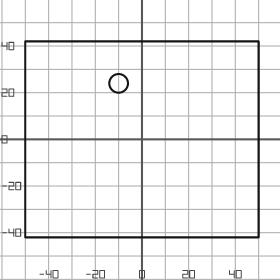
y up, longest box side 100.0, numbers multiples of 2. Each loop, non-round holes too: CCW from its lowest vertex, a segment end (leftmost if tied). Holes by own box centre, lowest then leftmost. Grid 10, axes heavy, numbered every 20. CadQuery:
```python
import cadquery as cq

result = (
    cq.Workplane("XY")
    .moveTo(-50.0, -42.0)
    .lineTo(50.0, -42.0)
    .lineTo(50.0, 42.0)
    .lineTo(-50.0, 42.0)
    .close()
    .moveTo(-10.0, 24.0)
    .circle(4.0)
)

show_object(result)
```